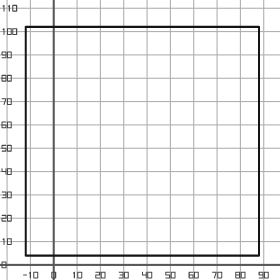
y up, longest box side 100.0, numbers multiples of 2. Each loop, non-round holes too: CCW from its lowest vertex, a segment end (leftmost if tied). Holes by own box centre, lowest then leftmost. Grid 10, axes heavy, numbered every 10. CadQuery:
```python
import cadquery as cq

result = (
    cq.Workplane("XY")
    .moveTo(-12.0, 4.0)
    .lineTo(88.0, 4.0)
    .lineTo(88.0, 102.0)
    .lineTo(-12.0, 102.0)
    .close()
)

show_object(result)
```